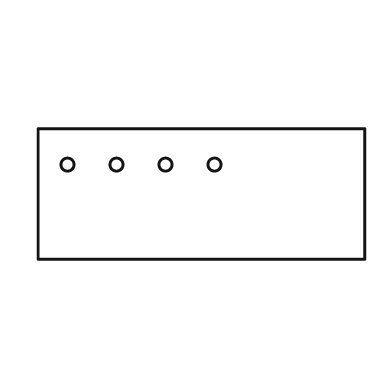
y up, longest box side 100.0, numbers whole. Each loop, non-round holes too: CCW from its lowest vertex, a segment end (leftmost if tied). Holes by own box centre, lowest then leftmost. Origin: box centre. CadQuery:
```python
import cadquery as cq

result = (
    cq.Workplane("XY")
    .moveTo(-50.0, -20.0)
    .lineTo(50.0, -20.0)
    .lineTo(50.0, 20.0)
    .lineTo(-50.0, 20.0)
    .close()
    .moveTo(-41.0, 9.0)
    .circle(2.0)
    .moveTo(-26.0, 9.0)
    .circle(2.0)
    .moveTo(-11.0, 9.0)
    .circle(2.0)
    .moveTo(4.0, 9.0)
    .circle(2.0)
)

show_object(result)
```